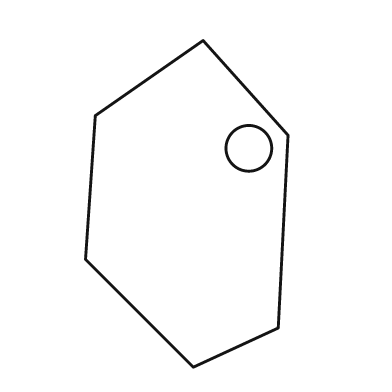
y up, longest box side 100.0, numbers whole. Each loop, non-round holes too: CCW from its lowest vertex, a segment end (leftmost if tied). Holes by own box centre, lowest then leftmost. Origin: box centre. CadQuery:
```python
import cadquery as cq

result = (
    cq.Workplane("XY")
    .moveTo(2.0, -50.0)
    .lineTo(28.0, -38.0)
    .lineTo(31.0, 21.0)
    .lineTo(5.0, 50.0)
    .lineTo(-28.0, 27.0)
    .lineTo(-31.0, -17.0)
    .close()
    .moveTo(19.0, 17.0)
    .circle(7.0)
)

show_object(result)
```